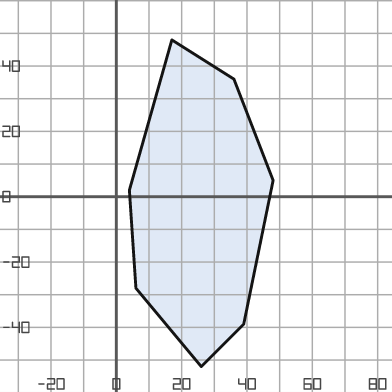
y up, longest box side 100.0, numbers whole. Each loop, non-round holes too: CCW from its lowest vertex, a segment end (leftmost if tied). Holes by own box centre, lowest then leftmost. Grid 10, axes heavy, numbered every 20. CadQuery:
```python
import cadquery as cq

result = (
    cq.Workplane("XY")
    .moveTo(26.0, -52.0)
    .lineTo(39.0, -39.0)
    .lineTo(48.0, 5.0)
    .lineTo(36.0, 36.0)
    .lineTo(17.0, 48.0)
    .lineTo(4.0, 2.0)
    .lineTo(6.0, -28.0)
    .close()
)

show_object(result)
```